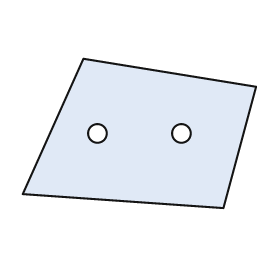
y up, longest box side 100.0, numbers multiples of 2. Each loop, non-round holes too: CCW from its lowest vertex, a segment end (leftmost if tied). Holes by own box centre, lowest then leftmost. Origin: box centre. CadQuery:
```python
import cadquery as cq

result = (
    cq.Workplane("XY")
    .moveTo(36.0, -32.0)
    .lineTo(50.0, 20.0)
    .lineTo(-24.0, 32.0)
    .lineTo(-50.0, -26.0)
    .close()
    .moveTo(-18.0, 0.0)
    .circle(4.0)
    .moveTo(18.0, 0.0)
    .circle(4.0)
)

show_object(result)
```